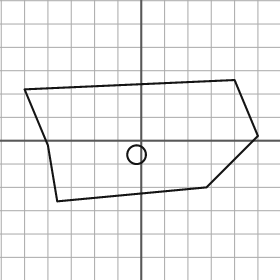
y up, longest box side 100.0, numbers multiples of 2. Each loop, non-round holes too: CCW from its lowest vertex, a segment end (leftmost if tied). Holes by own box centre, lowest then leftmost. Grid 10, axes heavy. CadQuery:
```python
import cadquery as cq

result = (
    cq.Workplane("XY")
    .moveTo(-36.0, -26.0)
    .lineTo(28.0, -20.0)
    .lineTo(50.0, 2.0)
    .lineTo(40.0, 26.0)
    .lineTo(-50.0, 22.0)
    .lineTo(-40.0, -2.0)
    .close()
    .moveTo(-2.0, -6.0)
    .circle(4.0)
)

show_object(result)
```